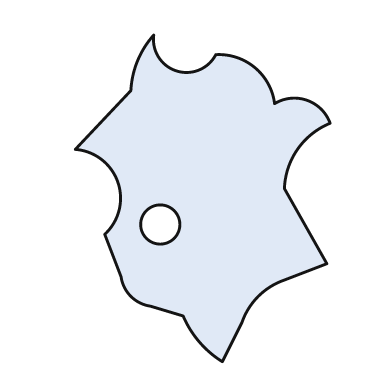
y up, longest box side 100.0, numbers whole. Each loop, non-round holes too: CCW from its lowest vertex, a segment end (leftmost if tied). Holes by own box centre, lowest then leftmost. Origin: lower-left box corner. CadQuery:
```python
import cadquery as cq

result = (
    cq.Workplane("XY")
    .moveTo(45.0, 0.0)
    .lineTo(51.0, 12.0)
    .threePointArc((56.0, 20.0), (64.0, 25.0))
    .lineTo(77.0, 30.0)
    .lineTo(64.0, 53.0)
    .threePointArc((68.0, 65.0), (78.0, 73.0))
    .threePointArc((71.0, 80.0), (61.0, 79.0))
    .threePointArc((55.0, 90.0), (43.0, 94.0))
    .threePointArc((31.0, 89.0), (24.0, 100.0))
    .threePointArc((19.0, 92.0), (17.0, 83.0))
    .lineTo(0.0, 65.0)
    .threePointArc((13.0, 55.0), (9.0, 39.0))
    .lineTo(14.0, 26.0)
    .threePointArc((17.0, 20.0), (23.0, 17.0))
    .lineTo(33.0, 14.0)
    .threePointArc((38.0, 6.0), (45.0, 0.0))
    .close()
    .moveTo(26.0, 42.0)
    .circle(6.0)
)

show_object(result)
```